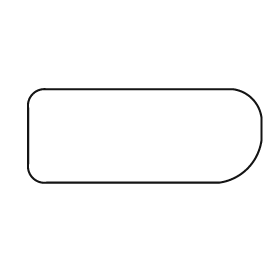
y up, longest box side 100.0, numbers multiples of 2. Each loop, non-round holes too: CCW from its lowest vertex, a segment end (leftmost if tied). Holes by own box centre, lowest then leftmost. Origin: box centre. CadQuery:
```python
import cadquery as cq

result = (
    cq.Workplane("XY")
    .moveTo(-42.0, -20.0)
    .lineTo(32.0, -20.0)
    .threePointArc((44.0, -14.0), (50.0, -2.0))
    .lineTo(50.0, 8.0)
    .threePointArc((46.0, 16.0), (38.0, 20.0))
    .lineTo(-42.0, 20.0)
    .threePointArc((-48.0, 18.0), (-50.0, 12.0))
    .lineTo(-50.0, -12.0)
    .threePointArc((-48.0, -18.0), (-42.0, -20.0))
    .close()
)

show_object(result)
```